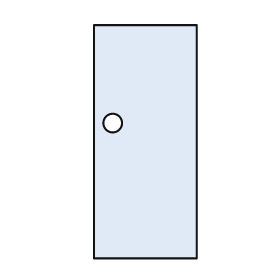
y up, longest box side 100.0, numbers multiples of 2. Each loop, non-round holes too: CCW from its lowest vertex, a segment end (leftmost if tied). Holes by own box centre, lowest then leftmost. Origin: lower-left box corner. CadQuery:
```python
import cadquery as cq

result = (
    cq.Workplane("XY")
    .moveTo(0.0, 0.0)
    .lineTo(44.0, 0.0)
    .lineTo(44.0, 100.0)
    .lineTo(0.0, 100.0)
    .close()
    .moveTo(8.0, 58.0)
    .circle(4.0)
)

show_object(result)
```